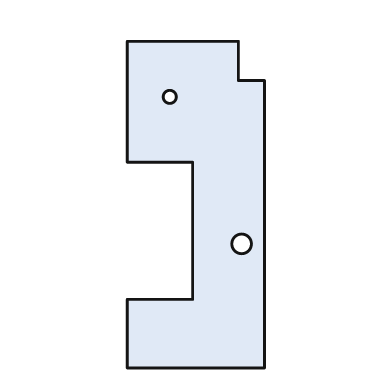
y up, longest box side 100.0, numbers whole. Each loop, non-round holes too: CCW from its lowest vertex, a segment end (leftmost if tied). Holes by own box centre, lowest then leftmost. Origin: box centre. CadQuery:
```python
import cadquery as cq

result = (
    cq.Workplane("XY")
    .moveTo(-21.0, -50.0)
    .lineTo(21.0, -50.0)
    .lineTo(21.0, 38.0)
    .lineTo(13.0, 38.0)
    .lineTo(13.0, 50.0)
    .lineTo(-21.0, 50.0)
    .lineTo(-21.0, 13.0)
    .lineTo(-1.0, 13.0)
    .lineTo(-1.0, -29.0)
    .lineTo(-21.0, -29.0)
    .close()
    .moveTo(14.0, -12.0)
    .circle(3.0)
    .moveTo(-8.0, 33.0)
    .circle(2.0)
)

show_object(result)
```